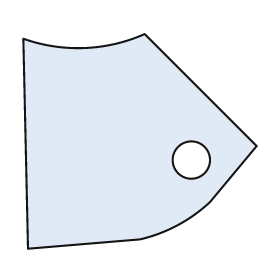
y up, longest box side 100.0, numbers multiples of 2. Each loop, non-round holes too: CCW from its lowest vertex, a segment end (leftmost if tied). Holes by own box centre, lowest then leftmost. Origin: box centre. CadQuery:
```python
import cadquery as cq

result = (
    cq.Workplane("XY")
    .moveTo(-48.0, -46.0)
    .lineTo(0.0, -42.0)
    .threePointArc((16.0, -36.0), (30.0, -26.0))
    .lineTo(50.0, -2.0)
    .lineTo(2.0, 46.0)
    .threePointArc((-24.0, 40.0), (-50.0, 44.0))
    .close()
    .moveTo(22.0, -8.0)
    .circle(8.0)
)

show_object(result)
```